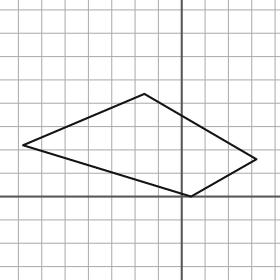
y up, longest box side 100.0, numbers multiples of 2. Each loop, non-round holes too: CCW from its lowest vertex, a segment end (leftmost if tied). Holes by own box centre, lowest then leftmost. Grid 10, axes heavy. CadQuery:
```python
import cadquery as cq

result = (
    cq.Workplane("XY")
    .moveTo(4.0, 0.0)
    .lineTo(32.0, 16.0)
    .lineTo(-16.0, 44.0)
    .lineTo(-68.0, 22.0)
    .close()
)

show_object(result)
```